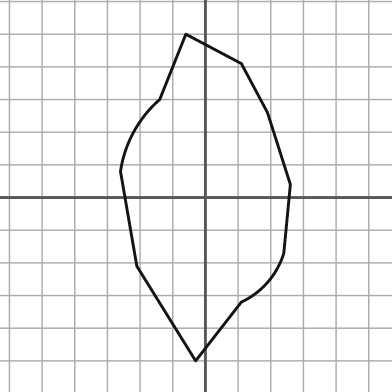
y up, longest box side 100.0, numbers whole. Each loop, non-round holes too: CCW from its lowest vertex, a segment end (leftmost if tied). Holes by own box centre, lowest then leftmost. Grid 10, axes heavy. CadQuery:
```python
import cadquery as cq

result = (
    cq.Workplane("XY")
    .moveTo(-3.0, -50.0)
    .lineTo(11.0, -32.0)
    .threePointArc((19.0, -26.0), (24.0, -17.0))
    .lineTo(26.0, 4.0)
    .lineTo(19.0, 26.0)
    .lineTo(11.0, 41.0)
    .lineTo(-6.0, 50.0)
    .lineTo(-14.0, 30.0)
    .threePointArc((-22.0, 20.0), (-26.0, 8.0))
    .lineTo(-21.0, -21.0)
    .close()
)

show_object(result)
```